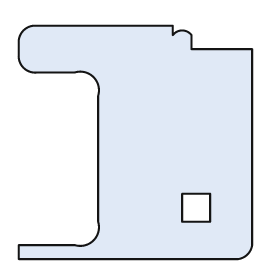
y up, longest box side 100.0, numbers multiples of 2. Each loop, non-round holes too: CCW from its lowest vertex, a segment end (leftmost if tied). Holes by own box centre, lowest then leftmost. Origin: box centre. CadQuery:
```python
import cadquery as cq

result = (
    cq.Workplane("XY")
    .moveTo(-50.0, -50.0)
    .lineTo(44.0, -50.0)
    .threePointArc((48.0, -48.0), (50.0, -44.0))
    .lineTo(50.0, 40.0)
    .lineTo(24.0, 40.0)
    .lineTo(24.0, 46.0)
    .threePointArc((20.0, 48.0), (16.0, 46.0))
    .lineTo(16.0, 50.0)
    .lineTo(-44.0, 50.0)
    .threePointArc((-48.0, 48.0), (-50.0, 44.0))
    .lineTo(-50.0, 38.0)
    .threePointArc((-48.0, 32.0), (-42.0, 30.0))
    .lineTo(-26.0, 30.0)
    .threePointArc((-18.0, 28.0), (-16.0, 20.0))
    .lineTo(-16.0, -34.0)
    .threePointArc((-18.0, -42.0), (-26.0, -44.0))
    .lineTo(-50.0, -44.0)
    .close()
    .moveTo(20.0, -34.0)
    .lineTo(32.0, -34.0)
    .lineTo(32.0, -22.0)
    .lineTo(20.0, -22.0)
    .close()
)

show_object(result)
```